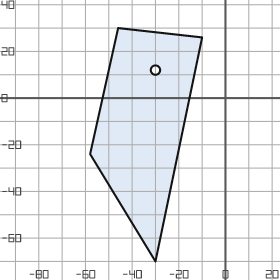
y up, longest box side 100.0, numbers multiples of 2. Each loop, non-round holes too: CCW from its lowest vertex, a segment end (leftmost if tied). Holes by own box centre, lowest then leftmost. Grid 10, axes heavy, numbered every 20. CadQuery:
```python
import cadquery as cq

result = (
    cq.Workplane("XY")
    .moveTo(-30.0, -70.0)
    .lineTo(-10.0, 26.0)
    .lineTo(-46.0, 30.0)
    .lineTo(-58.0, -24.0)
    .close()
    .moveTo(-30.0, 12.0)
    .circle(2.0)
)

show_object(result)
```